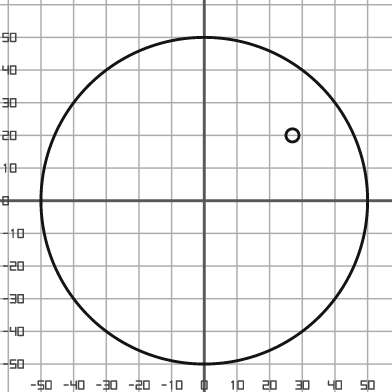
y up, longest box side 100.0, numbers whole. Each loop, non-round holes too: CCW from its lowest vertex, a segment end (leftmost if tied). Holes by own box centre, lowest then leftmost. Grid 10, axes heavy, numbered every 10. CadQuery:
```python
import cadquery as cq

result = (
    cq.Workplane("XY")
    .moveTo(0.0, 0.0)
    .circle(50.0)
    .moveTo(27.0, 20.0)
    .circle(2.0)
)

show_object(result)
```